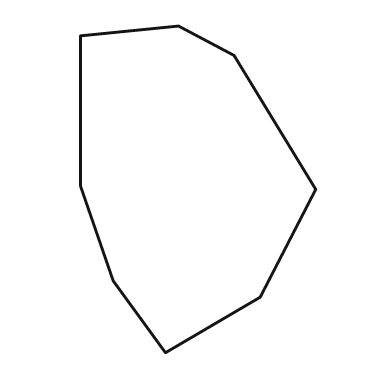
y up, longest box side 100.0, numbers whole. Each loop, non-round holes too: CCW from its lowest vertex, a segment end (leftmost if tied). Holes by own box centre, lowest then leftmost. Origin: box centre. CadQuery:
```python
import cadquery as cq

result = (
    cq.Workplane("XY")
    .moveTo(-10.0, -50.0)
    .lineTo(19.0, -33.0)
    .lineTo(36.0, 0.0)
    .lineTo(11.0, 41.0)
    .lineTo(-6.0, 50.0)
    .lineTo(-36.0, 47.0)
    .lineTo(-36.0, 1.0)
    .lineTo(-26.0, -28.0)
    .close()
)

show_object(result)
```